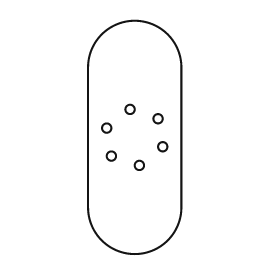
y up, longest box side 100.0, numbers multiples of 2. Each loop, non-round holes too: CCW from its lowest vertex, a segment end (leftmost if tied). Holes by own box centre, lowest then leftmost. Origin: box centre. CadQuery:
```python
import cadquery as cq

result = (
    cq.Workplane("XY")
    .moveTo(-20.0, -30.0)
    .threePointArc((0.0, -50.0), (20.0, -30.0))
    .lineTo(20.0, 30.0)
    .threePointArc((0.0, 50.0), (-20.0, 30.0))
    .close()
    .moveTo(2.0, -12.0)
    .circle(2.0)
    .moveTo(-10.0, -8.0)
    .circle(2.0)
    .moveTo(12.0, -4.0)
    .circle(2.0)
    .moveTo(-12.0, 4.0)
    .circle(2.0)
    .moveTo(10.0, 8.0)
    .circle(2.0)
    .moveTo(-2.0, 12.0)
    .circle(2.0)
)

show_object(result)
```